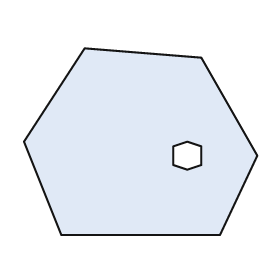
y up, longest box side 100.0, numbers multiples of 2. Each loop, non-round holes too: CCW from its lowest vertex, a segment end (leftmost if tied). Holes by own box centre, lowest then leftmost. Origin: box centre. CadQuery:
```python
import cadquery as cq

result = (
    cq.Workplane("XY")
    .moveTo(-34.0, -40.0)
    .lineTo(34.0, -40.0)
    .lineTo(50.0, -6.0)
    .lineTo(26.0, 36.0)
    .lineTo(-24.0, 40.0)
    .lineTo(-50.0, 0.0)
    .close()
    .moveTo(20.0, -12.0)
    .lineTo(26.0, -10.0)
    .lineTo(26.0, -2.0)
    .lineTo(20.0, 0.0)
    .lineTo(14.0, -2.0)
    .lineTo(14.0, -10.0)
    .close()
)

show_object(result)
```